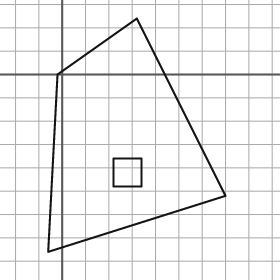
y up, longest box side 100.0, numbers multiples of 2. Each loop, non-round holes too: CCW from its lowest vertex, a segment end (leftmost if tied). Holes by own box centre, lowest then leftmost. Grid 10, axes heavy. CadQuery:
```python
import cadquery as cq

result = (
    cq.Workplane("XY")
    .moveTo(-6.0, -76.0)
    .lineTo(70.0, -52.0)
    .lineTo(32.0, 24.0)
    .lineTo(-2.0, 0.0)
    .close()
    .moveTo(22.0, -48.0)
    .lineTo(34.0, -48.0)
    .lineTo(34.0, -36.0)
    .lineTo(22.0, -36.0)
    .close()
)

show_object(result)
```